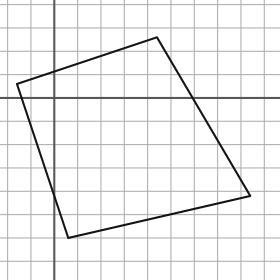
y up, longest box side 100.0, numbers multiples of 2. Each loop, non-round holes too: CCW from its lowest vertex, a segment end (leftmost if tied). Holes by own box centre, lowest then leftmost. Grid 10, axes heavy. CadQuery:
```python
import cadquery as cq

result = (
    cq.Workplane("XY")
    .moveTo(6.0, -60.0)
    .lineTo(84.0, -42.0)
    .lineTo(44.0, 26.0)
    .lineTo(-16.0, 6.0)
    .close()
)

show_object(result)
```